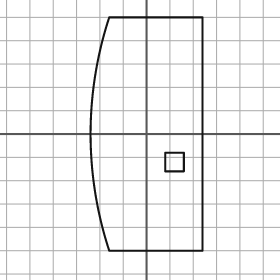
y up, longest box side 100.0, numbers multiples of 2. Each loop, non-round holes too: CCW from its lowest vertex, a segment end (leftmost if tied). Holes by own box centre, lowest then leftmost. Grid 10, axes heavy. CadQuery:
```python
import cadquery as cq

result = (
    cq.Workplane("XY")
    .moveTo(-16.0, -50.0)
    .lineTo(24.0, -50.0)
    .lineTo(24.0, 50.0)
    .lineTo(-16.0, 50.0)
    .threePointArc((-24.0, 0.0), (-16.0, -50.0))
    .close()
    .moveTo(8.0, -16.0)
    .lineTo(16.0, -16.0)
    .lineTo(16.0, -8.0)
    .lineTo(8.0, -8.0)
    .close()
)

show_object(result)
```